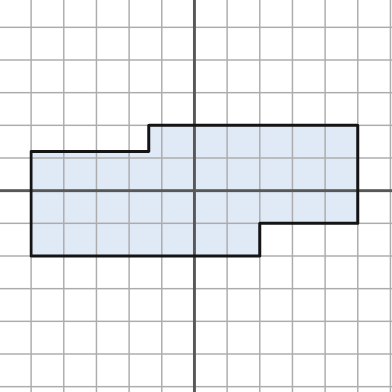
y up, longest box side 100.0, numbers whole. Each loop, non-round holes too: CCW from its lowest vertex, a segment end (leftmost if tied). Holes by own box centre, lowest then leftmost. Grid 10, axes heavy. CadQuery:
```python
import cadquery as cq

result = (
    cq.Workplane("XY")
    .moveTo(-50.0, -20.0)
    .lineTo(20.0, -20.0)
    .lineTo(20.0, -10.0)
    .lineTo(50.0, -10.0)
    .lineTo(50.0, 20.0)
    .lineTo(-14.0, 20.0)
    .lineTo(-14.0, 12.0)
    .lineTo(-50.0, 12.0)
    .close()
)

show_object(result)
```